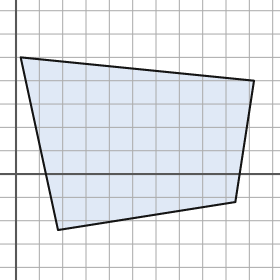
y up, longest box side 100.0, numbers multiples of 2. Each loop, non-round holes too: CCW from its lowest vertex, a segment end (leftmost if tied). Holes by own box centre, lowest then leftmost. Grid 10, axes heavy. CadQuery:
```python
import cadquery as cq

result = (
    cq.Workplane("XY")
    .moveTo(18.0, -24.0)
    .lineTo(94.0, -12.0)
    .lineTo(102.0, 40.0)
    .lineTo(2.0, 50.0)
    .close()
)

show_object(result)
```